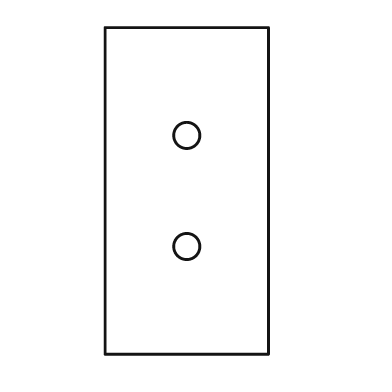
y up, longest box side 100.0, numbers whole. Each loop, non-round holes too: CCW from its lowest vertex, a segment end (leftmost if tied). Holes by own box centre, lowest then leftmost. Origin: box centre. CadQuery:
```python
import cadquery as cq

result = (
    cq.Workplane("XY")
    .moveTo(-25.0, -50.0)
    .lineTo(25.0, -50.0)
    .lineTo(25.0, 50.0)
    .lineTo(-25.0, 50.0)
    .close()
    .moveTo(0.0, -17.0)
    .circle(4.0)
    .moveTo(0.0, 17.0)
    .circle(4.0)
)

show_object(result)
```